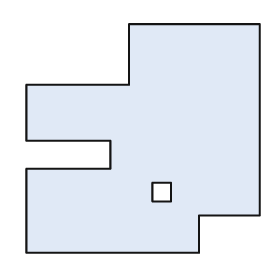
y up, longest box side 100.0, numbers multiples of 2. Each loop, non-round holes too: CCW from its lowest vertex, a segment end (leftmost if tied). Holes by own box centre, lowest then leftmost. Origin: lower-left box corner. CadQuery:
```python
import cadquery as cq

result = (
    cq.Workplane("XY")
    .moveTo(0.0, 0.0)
    .lineTo(74.0, 0.0)
    .lineTo(74.0, 16.0)
    .lineTo(100.0, 16.0)
    .lineTo(100.0, 98.0)
    .lineTo(44.0, 98.0)
    .lineTo(44.0, 72.0)
    .lineTo(0.0, 72.0)
    .lineTo(0.0, 48.0)
    .lineTo(36.0, 48.0)
    .lineTo(36.0, 36.0)
    .lineTo(0.0, 36.0)
    .close()
    .moveTo(54.0, 22.0)
    .lineTo(62.0, 22.0)
    .lineTo(62.0, 30.0)
    .lineTo(54.0, 30.0)
    .close()
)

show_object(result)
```